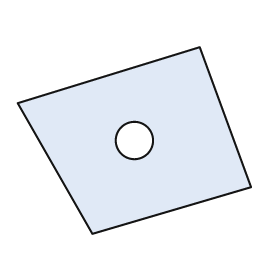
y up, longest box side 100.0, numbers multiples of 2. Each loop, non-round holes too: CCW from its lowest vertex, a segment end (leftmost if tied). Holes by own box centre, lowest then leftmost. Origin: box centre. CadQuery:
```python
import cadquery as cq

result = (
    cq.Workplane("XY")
    .moveTo(-18.0, -40.0)
    .lineTo(50.0, -20.0)
    .lineTo(28.0, 40.0)
    .lineTo(-50.0, 16.0)
    .close()
    .moveTo(0.0, 0.0)
    .circle(8.0)
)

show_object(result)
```